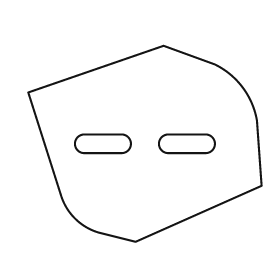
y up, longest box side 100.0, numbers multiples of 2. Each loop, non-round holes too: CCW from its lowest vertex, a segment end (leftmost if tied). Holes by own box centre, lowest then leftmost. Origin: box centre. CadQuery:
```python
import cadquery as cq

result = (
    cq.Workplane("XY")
    .moveTo(-4.0, -42.0)
    .lineTo(50.0, -18.0)
    .lineTo(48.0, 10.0)
    .threePointArc((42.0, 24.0), (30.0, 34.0))
    .lineTo(8.0, 42.0)
    .lineTo(-50.0, 22.0)
    .lineTo(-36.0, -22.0)
    .threePointArc((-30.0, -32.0), (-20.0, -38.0))
    .close()
    .moveTo(-26.0, -4.0)
    .lineTo(-10.0, -4.0)
    .threePointArc((-6.0, 0.0), (-10.0, 4.0))
    .lineTo(-26.0, 4.0)
    .threePointArc((-30.0, 0.0), (-26.0, -4.0))
    .close()
    .moveTo(10.0, -4.0)
    .lineTo(26.0, -4.0)
    .threePointArc((30.0, 0.0), (26.0, 4.0))
    .lineTo(10.0, 4.0)
    .threePointArc((6.0, 0.0), (10.0, -4.0))
    .close()
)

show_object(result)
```